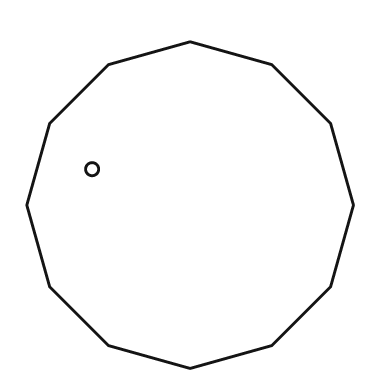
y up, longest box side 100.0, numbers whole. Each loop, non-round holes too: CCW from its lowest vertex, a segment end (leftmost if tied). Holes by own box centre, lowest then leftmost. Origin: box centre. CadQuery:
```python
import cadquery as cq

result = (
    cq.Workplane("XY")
    .moveTo(0.0, -50.0)
    .lineTo(25.0, -43.0)
    .lineTo(43.0, -25.0)
    .lineTo(50.0, 0.0)
    .lineTo(43.0, 25.0)
    .lineTo(25.0, 43.0)
    .lineTo(0.0, 50.0)
    .lineTo(-25.0, 43.0)
    .lineTo(-43.0, 25.0)
    .lineTo(-50.0, 0.0)
    .lineTo(-43.0, -25.0)
    .lineTo(-25.0, -43.0)
    .close()
    .moveTo(-30.0, 11.0)
    .circle(2.0)
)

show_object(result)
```